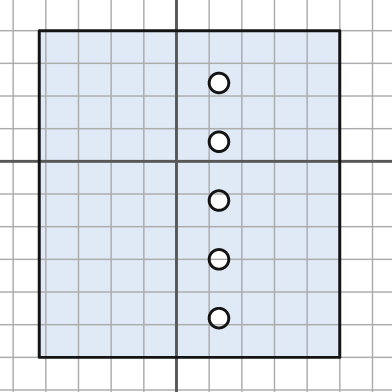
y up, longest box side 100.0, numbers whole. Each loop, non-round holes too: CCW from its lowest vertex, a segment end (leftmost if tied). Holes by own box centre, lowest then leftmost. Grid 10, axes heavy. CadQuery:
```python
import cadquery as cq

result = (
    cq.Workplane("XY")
    .moveTo(-42.0, -60.0)
    .lineTo(50.0, -60.0)
    .lineTo(50.0, 40.0)
    .lineTo(-42.0, 40.0)
    .close()
    .moveTo(13.0, -48.0)
    .circle(3.0)
    .moveTo(13.0, -30.0)
    .circle(3.0)
    .moveTo(13.0, -12.0)
    .circle(3.0)
    .moveTo(13.0, 6.0)
    .circle(3.0)
    .moveTo(13.0, 24.0)
    .circle(3.0)
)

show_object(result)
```